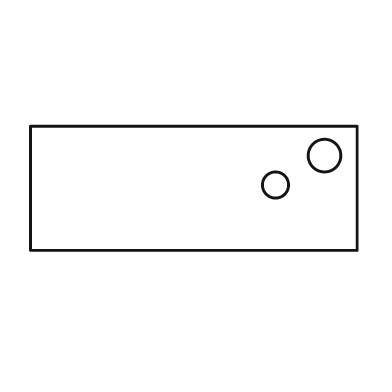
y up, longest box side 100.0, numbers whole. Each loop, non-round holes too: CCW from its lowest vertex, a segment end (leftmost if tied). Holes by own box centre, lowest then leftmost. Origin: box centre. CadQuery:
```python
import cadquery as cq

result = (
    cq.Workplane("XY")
    .moveTo(-50.0, -19.0)
    .lineTo(50.0, -19.0)
    .lineTo(50.0, 19.0)
    .lineTo(-50.0, 19.0)
    .close()
    .moveTo(25.0, 1.0)
    .circle(4.0)
    .moveTo(40.0, 10.0)
    .circle(5.0)
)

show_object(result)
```